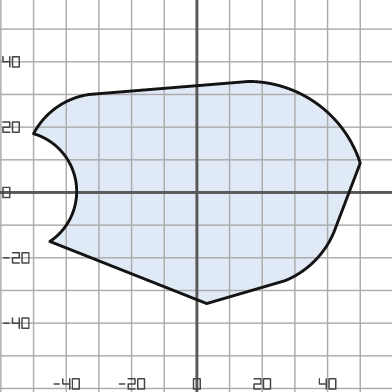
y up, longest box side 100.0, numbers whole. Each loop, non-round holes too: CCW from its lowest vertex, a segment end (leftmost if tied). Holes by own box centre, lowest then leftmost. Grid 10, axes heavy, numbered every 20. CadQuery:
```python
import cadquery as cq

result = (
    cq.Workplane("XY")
    .moveTo(3.0, -34.0)
    .lineTo(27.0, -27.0)
    .threePointArc((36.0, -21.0), (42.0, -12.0))
    .lineTo(50.0, 9.0)
    .threePointArc((37.0, 27.0), (16.0, 34.0))
    .lineTo(-33.0, 30.0)
    .threePointArc((-43.0, 26.0), (-50.0, 18.0))
    .threePointArc((-37.0, 3.0), (-45.0, -15.0))
    .close()
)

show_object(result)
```